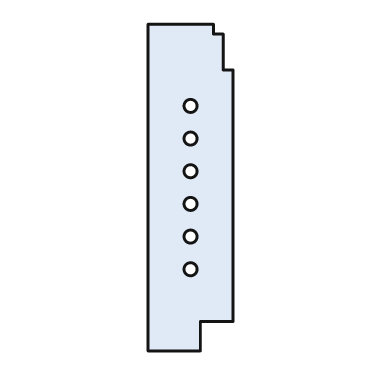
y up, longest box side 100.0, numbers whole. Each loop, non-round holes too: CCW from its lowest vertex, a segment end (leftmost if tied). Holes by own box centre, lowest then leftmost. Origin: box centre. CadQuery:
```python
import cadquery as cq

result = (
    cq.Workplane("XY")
    .moveTo(-13.0, -50.0)
    .lineTo(3.0, -50.0)
    .lineTo(3.0, -41.0)
    .lineTo(13.0, -41.0)
    .lineTo(13.0, 36.0)
    .lineTo(10.0, 36.0)
    .lineTo(10.0, 47.0)
    .lineTo(7.0, 47.0)
    .lineTo(7.0, 50.0)
    .lineTo(-13.0, 50.0)
    .close()
    .moveTo(0.0, -25.0)
    .circle(2.0)
    .moveTo(0.0, -15.0)
    .circle(2.0)
    .moveTo(0.0, -5.0)
    .circle(2.0)
    .moveTo(0.0, 5.0)
    .circle(2.0)
    .moveTo(0.0, 15.0)
    .circle(2.0)
    .moveTo(0.0, 25.0)
    .circle(2.0)
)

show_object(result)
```